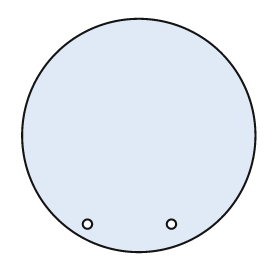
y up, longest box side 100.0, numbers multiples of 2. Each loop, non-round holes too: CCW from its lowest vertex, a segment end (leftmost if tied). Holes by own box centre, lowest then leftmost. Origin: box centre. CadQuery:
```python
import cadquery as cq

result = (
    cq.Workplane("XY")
    .moveTo(0.0, 0.0)
    .circle(50.0)
    .moveTo(-22.0, -38.0)
    .circle(2.0)
    .moveTo(14.0, -38.0)
    .circle(2.0)
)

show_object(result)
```